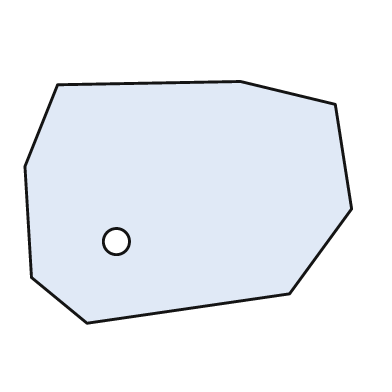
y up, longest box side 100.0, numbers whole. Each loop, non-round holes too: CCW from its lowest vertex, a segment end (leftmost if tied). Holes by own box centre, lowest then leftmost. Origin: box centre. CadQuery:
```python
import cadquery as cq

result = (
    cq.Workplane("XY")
    .moveTo(-31.0, -37.0)
    .lineTo(31.0, -28.0)
    .lineTo(50.0, -2.0)
    .lineTo(45.0, 30.0)
    .lineTo(16.0, 37.0)
    .lineTo(-40.0, 36.0)
    .lineTo(-50.0, 11.0)
    .lineTo(-48.0, -23.0)
    .close()
    .moveTo(-22.0, -12.0)
    .circle(4.0)
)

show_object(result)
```